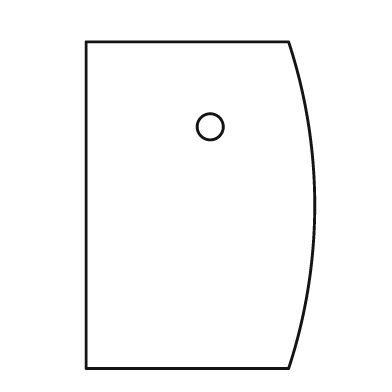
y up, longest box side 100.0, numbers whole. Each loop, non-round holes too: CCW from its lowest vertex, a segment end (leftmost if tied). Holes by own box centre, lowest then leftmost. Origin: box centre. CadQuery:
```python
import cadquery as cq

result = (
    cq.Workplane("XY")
    .moveTo(-35.0, -50.0)
    .lineTo(27.0, -50.0)
    .threePointArc((35.0, 0.0), (27.0, 50.0))
    .lineTo(-35.0, 50.0)
    .close()
    .moveTo(3.0, 24.0)
    .circle(4.0)
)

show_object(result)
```